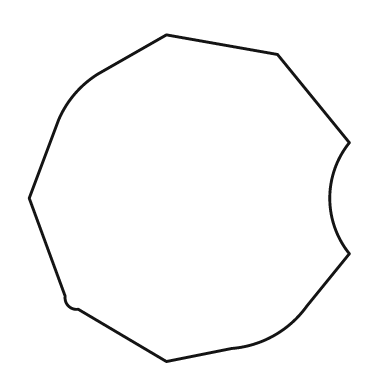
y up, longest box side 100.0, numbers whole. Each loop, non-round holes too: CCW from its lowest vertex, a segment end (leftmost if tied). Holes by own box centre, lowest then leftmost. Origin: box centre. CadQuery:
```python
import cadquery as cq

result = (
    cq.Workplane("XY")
    .moveTo(-7.0, -50.0)
    .lineTo(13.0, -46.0)
    .threePointArc((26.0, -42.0), (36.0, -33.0))
    .lineTo(49.0, -17.0)
    .threePointArc((43.0, 0.0), (49.0, 17.0))
    .lineTo(27.0, 44.0)
    .lineTo(-7.0, 50.0)
    .lineTo(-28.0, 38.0)
    .threePointArc((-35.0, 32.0), (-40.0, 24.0))
    .lineTo(-49.0, 0.0)
    .lineTo(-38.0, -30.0)
    .threePointArc((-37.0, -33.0), (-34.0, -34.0))
    .close()
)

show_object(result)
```